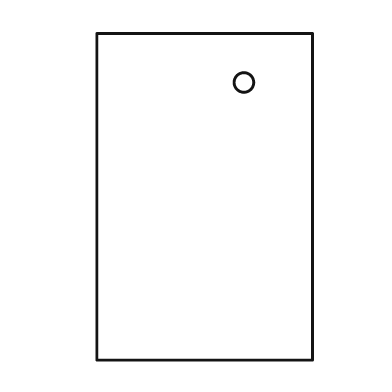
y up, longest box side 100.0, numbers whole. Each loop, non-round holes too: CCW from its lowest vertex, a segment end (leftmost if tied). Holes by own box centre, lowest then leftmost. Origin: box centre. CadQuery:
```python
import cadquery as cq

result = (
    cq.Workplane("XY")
    .moveTo(-33.0, -50.0)
    .lineTo(33.0, -50.0)
    .lineTo(33.0, 50.0)
    .lineTo(-33.0, 50.0)
    .close()
    .moveTo(12.0, 35.0)
    .circle(3.0)
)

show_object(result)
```